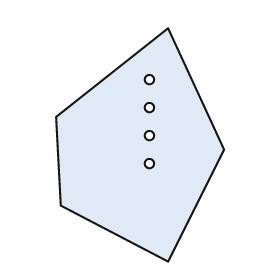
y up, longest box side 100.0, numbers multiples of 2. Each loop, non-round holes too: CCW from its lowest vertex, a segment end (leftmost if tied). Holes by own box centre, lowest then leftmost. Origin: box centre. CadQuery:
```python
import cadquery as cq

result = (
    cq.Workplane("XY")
    .moveTo(12.0, -50.0)
    .lineTo(36.0, -2.0)
    .lineTo(12.0, 50.0)
    .lineTo(-36.0, 12.0)
    .lineTo(-34.0, -26.0)
    .close()
    .moveTo(4.0, -8.0)
    .circle(2.0)
    .moveTo(4.0, 4.0)
    .circle(2.0)
    .moveTo(4.0, 16.0)
    .circle(2.0)
    .moveTo(4.0, 28.0)
    .circle(2.0)
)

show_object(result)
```